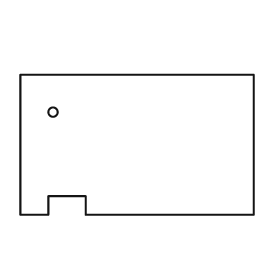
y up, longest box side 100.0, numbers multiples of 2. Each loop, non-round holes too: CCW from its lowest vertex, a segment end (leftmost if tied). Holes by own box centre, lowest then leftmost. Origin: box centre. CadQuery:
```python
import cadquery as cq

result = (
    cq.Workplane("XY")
    .moveTo(-50.0, -30.0)
    .lineTo(-38.0, -30.0)
    .lineTo(-38.0, -22.0)
    .lineTo(-22.0, -22.0)
    .lineTo(-22.0, -30.0)
    .lineTo(50.0, -30.0)
    .lineTo(50.0, 30.0)
    .lineTo(-50.0, 30.0)
    .close()
    .moveTo(-36.0, 14.0)
    .circle(2.0)
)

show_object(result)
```